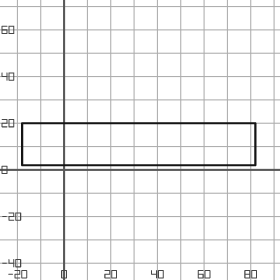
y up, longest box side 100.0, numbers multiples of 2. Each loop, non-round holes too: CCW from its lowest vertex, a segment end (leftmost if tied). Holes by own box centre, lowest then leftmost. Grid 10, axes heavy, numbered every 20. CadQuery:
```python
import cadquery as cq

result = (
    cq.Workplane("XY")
    .moveTo(-18.0, 2.0)
    .lineTo(82.0, 2.0)
    .lineTo(82.0, 20.0)
    .lineTo(-18.0, 20.0)
    .close()
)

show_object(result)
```